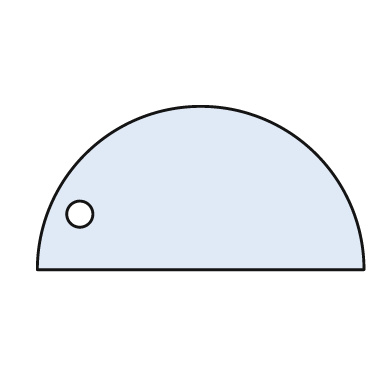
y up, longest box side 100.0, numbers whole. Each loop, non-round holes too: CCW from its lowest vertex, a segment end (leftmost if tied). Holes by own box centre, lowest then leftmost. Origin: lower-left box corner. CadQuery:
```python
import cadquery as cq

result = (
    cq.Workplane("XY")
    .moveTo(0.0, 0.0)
    .lineTo(100.0, 0.0)
    .threePointArc((50.0, 50.0), (0.0, 0.0))
    .close()
    .moveTo(13.0, 17.0)
    .circle(4.0)
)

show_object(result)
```